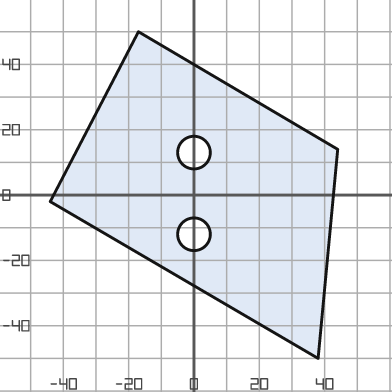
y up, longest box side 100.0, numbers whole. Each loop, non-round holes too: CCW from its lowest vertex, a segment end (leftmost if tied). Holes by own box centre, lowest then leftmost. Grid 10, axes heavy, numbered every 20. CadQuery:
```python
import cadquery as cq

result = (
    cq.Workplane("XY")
    .moveTo(38.0, -50.0)
    .lineTo(44.0, 14.0)
    .lineTo(-17.0, 50.0)
    .lineTo(-44.0, -2.0)
    .close()
    .moveTo(0.0, -12.0)
    .circle(5.0)
    .moveTo(0.0, 13.0)
    .circle(5.0)
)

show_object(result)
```